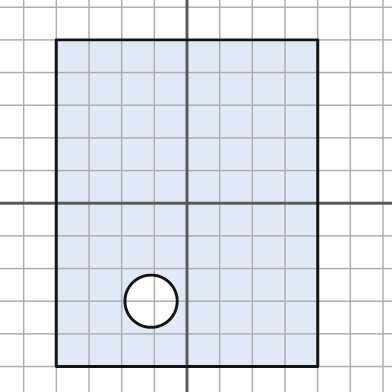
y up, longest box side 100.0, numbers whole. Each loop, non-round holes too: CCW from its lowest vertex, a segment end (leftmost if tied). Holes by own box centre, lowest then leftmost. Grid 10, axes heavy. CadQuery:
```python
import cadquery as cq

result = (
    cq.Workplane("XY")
    .moveTo(-40.0, -50.0)
    .lineTo(40.0, -50.0)
    .lineTo(40.0, 50.0)
    .lineTo(-40.0, 50.0)
    .close()
    .moveTo(-11.0, -30.0)
    .circle(8.0)
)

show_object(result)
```